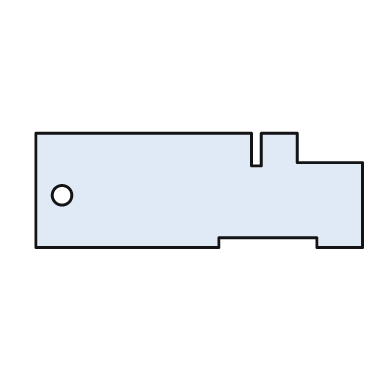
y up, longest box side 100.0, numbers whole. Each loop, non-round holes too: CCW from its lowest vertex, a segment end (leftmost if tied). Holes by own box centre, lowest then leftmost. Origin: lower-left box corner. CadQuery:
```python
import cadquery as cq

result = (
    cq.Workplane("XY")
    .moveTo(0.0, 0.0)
    .lineTo(56.0, 0.0)
    .lineTo(56.0, 3.0)
    .lineTo(86.0, 3.0)
    .lineTo(86.0, 0.0)
    .lineTo(100.0, 0.0)
    .lineTo(100.0, 26.0)
    .lineTo(80.0, 26.0)
    .lineTo(80.0, 35.0)
    .lineTo(69.0, 35.0)
    .lineTo(69.0, 25.0)
    .lineTo(66.0, 25.0)
    .lineTo(66.0, 35.0)
    .lineTo(0.0, 35.0)
    .close()
    .moveTo(8.0, 16.0)
    .circle(3.0)
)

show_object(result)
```